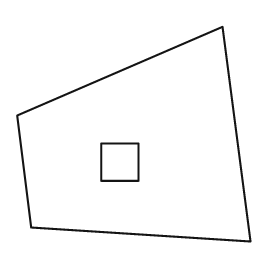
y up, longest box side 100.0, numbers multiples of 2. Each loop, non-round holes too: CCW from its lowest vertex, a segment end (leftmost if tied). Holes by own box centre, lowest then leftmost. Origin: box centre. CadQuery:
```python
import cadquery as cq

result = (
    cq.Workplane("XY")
    .moveTo(50.0, -46.0)
    .lineTo(38.0, 46.0)
    .lineTo(-50.0, 8.0)
    .lineTo(-44.0, -40.0)
    .close()
    .moveTo(-14.0, -20.0)
    .lineTo(2.0, -20.0)
    .lineTo(2.0, -4.0)
    .lineTo(-14.0, -4.0)
    .close()
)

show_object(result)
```